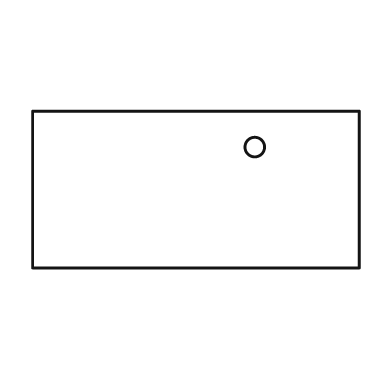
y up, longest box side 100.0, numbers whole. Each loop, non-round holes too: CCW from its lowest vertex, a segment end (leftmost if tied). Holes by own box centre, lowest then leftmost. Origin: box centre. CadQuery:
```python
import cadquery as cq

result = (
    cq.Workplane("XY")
    .moveTo(-50.0, -24.0)
    .lineTo(50.0, -24.0)
    .lineTo(50.0, 24.0)
    .lineTo(-50.0, 24.0)
    .close()
    .moveTo(18.0, 13.0)
    .circle(3.0)
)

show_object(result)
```